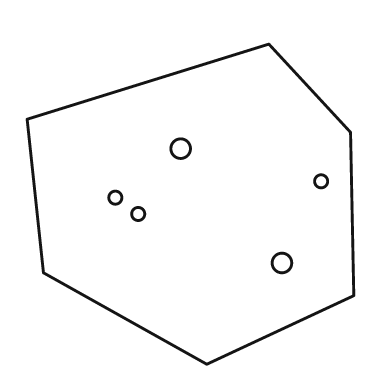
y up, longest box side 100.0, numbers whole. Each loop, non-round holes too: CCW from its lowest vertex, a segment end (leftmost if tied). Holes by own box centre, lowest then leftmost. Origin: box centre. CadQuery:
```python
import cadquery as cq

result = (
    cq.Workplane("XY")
    .moveTo(5.0, -49.0)
    .lineTo(50.0, -28.0)
    .lineTo(49.0, 22.0)
    .lineTo(24.0, 49.0)
    .lineTo(-50.0, 26.0)
    .lineTo(-45.0, -21.0)
    .close()
    .moveTo(28.0, -18.0)
    .circle(3.0)
    .moveTo(-16.0, -3.0)
    .circle(2.0)
    .moveTo(-23.0, 2.0)
    .circle(2.0)
    .moveTo(40.0, 7.0)
    .circle(2.0)
    .moveTo(-3.0, 17.0)
    .circle(3.0)
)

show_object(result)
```